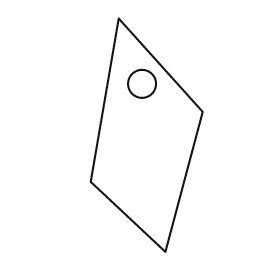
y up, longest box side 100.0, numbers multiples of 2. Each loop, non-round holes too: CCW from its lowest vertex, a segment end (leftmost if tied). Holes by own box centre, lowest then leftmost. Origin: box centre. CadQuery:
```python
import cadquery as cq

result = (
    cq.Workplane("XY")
    .moveTo(8.0, -50.0)
    .lineTo(24.0, 10.0)
    .lineTo(-12.0, 50.0)
    .lineTo(-24.0, -20.0)
    .close()
    .moveTo(-2.0, 22.0)
    .circle(6.0)
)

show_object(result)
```